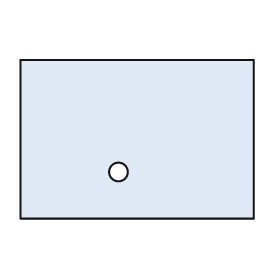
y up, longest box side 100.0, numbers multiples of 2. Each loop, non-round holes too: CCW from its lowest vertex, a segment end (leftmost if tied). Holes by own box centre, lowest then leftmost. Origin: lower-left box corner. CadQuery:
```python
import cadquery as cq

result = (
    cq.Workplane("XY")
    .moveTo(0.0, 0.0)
    .lineTo(100.0, 0.0)
    .lineTo(100.0, 68.0)
    .lineTo(0.0, 68.0)
    .close()
    .moveTo(42.0, 20.0)
    .circle(4.0)
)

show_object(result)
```